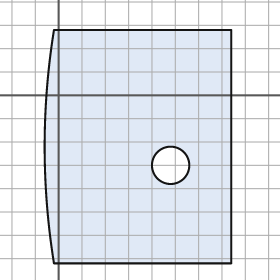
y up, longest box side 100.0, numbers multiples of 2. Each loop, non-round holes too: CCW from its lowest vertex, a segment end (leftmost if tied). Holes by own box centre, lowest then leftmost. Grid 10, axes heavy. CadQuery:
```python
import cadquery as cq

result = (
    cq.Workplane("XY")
    .moveTo(-2.0, -72.0)
    .lineTo(74.0, -72.0)
    .lineTo(74.0, 28.0)
    .lineTo(-2.0, 28.0)
    .threePointArc((-6.0, -22.0), (-2.0, -72.0))
    .close()
    .moveTo(48.0, -30.0)
    .circle(8.0)
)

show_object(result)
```